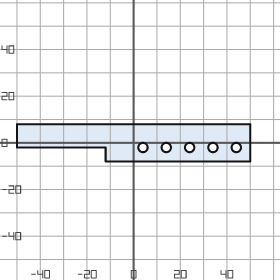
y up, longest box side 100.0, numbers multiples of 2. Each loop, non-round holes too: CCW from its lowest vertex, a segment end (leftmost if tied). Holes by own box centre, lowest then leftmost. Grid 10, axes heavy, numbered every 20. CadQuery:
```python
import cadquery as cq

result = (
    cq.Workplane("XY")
    .moveTo(-12.0, -8.0)
    .lineTo(50.0, -8.0)
    .lineTo(50.0, 8.0)
    .lineTo(-50.0, 8.0)
    .lineTo(-50.0, -2.0)
    .lineTo(-12.0, -2.0)
    .close()
    .moveTo(4.0, -2.0)
    .circle(2.0)
    .moveTo(14.0, -2.0)
    .circle(2.0)
    .moveTo(24.0, -2.0)
    .circle(2.0)
    .moveTo(34.0, -2.0)
    .circle(2.0)
    .moveTo(44.0, -2.0)
    .circle(2.0)
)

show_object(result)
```